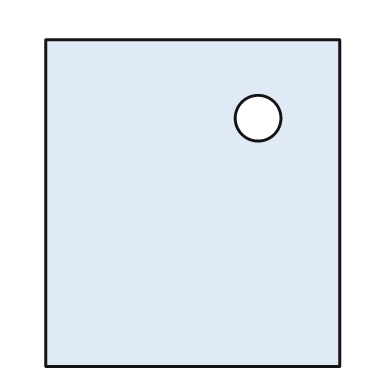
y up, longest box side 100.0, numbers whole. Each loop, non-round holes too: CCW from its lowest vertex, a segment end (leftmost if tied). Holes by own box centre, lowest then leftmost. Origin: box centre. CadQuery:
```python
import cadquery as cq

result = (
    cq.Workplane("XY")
    .moveTo(-45.0, -50.0)
    .lineTo(45.0, -50.0)
    .lineTo(45.0, 50.0)
    .lineTo(-45.0, 50.0)
    .close()
    .moveTo(20.0, 26.0)
    .circle(7.0)
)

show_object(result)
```